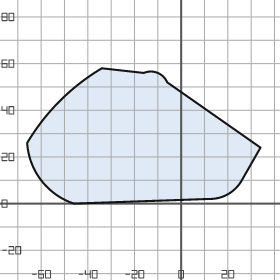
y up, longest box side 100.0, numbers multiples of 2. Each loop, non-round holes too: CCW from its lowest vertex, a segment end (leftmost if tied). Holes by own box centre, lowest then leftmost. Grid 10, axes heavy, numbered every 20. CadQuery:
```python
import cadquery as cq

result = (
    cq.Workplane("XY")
    .moveTo(-46.0, 0.0)
    .lineTo(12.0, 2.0)
    .threePointArc((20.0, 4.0), (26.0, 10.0))
    .lineTo(34.0, 24.0)
    .lineTo(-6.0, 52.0)
    .threePointArc((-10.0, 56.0), (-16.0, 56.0))
    .lineTo(-34.0, 58.0)
    .threePointArc((-52.0, 44.0), (-66.0, 26.0))
    .threePointArc((-60.0, 10.0), (-46.0, 0.0))
    .close()
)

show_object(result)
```